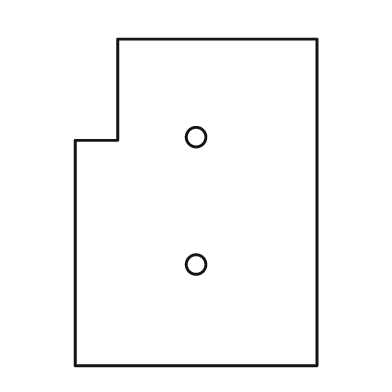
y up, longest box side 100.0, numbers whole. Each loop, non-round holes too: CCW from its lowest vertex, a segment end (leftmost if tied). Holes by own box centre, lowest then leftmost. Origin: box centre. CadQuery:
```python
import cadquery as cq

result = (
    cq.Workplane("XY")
    .moveTo(-37.0, -50.0)
    .lineTo(37.0, -50.0)
    .lineTo(37.0, 50.0)
    .lineTo(-24.0, 50.0)
    .lineTo(-24.0, 19.0)
    .lineTo(-37.0, 19.0)
    .close()
    .moveTo(0.0, -19.0)
    .circle(3.0)
    .moveTo(0.0, 20.0)
    .circle(3.0)
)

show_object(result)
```